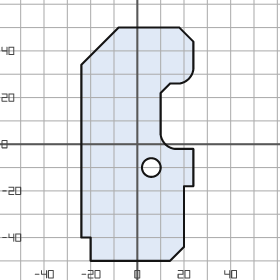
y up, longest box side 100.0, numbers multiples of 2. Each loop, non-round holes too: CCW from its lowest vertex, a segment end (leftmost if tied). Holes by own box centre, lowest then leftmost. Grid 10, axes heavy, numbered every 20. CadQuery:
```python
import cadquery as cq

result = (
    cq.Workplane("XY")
    .moveTo(-20.0, -50.0)
    .lineTo(14.0, -50.0)
    .lineTo(20.0, -44.0)
    .lineTo(20.0, -18.0)
    .lineTo(24.0, -18.0)
    .lineTo(24.0, -2.0)
    .lineTo(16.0, -2.0)
    .threePointArc((12.0, 0.0), (10.0, 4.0))
    .lineTo(10.0, 22.0)
    .lineTo(14.0, 26.0)
    .lineTo(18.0, 26.0)
    .threePointArc((22.0, 28.0), (24.0, 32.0))
    .lineTo(24.0, 44.0)
    .lineTo(18.0, 50.0)
    .lineTo(-8.0, 50.0)
    .lineTo(-24.0, 34.0)
    .lineTo(-24.0, -40.0)
    .lineTo(-20.0, -40.0)
    .close()
    .moveTo(6.0, -10.0)
    .circle(4.0)
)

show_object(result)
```